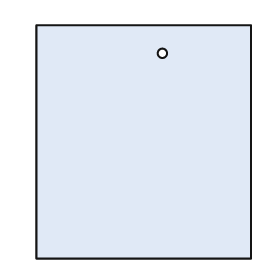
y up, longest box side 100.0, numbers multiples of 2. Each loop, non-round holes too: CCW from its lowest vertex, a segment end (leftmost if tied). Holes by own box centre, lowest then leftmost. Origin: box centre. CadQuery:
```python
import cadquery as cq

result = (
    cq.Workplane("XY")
    .moveTo(-46.0, -50.0)
    .lineTo(46.0, -50.0)
    .lineTo(46.0, 50.0)
    .lineTo(-46.0, 50.0)
    .close()
    .moveTo(8.0, 38.0)
    .circle(2.0)
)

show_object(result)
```